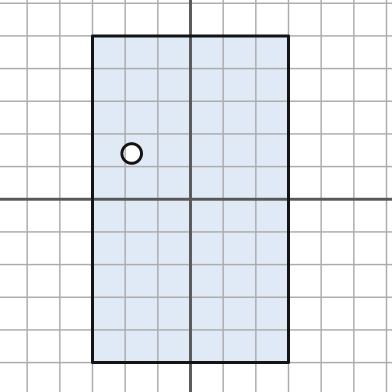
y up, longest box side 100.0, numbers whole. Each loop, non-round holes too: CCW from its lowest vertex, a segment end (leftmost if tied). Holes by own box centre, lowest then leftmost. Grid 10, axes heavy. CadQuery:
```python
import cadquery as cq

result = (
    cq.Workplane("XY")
    .moveTo(-30.0, -50.0)
    .lineTo(30.0, -50.0)
    .lineTo(30.0, 50.0)
    .lineTo(-30.0, 50.0)
    .close()
    .moveTo(-18.0, 14.0)
    .circle(3.0)
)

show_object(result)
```